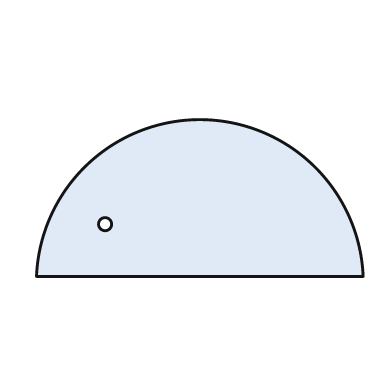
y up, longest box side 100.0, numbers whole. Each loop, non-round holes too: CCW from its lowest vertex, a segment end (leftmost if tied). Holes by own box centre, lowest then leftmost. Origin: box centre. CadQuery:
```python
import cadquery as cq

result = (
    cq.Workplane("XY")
    .moveTo(-50.0, -24.0)
    .lineTo(50.0, -24.0)
    .threePointArc((0.0, 24.0), (-50.0, -24.0))
    .close()
    .moveTo(-29.0, -8.0)
    .circle(2.0)
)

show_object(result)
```